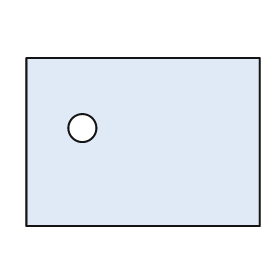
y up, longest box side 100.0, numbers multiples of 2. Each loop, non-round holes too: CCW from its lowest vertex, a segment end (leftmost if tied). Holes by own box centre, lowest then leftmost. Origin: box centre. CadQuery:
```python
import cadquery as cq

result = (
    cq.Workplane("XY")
    .moveTo(-50.0, -36.0)
    .lineTo(50.0, -36.0)
    .lineTo(50.0, 36.0)
    .lineTo(-50.0, 36.0)
    .close()
    .moveTo(-26.0, 6.0)
    .circle(6.0)
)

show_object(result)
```